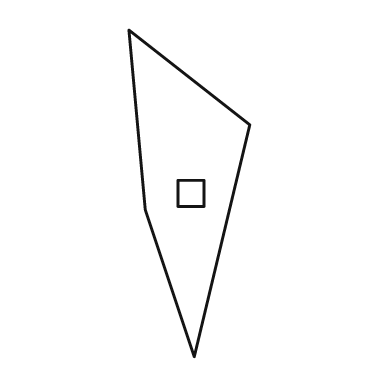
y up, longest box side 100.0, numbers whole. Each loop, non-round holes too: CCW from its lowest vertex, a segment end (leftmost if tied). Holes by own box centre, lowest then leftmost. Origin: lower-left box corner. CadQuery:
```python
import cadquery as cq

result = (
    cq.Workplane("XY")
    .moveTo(20.0, 0.0)
    .lineTo(37.0, 71.0)
    .lineTo(0.0, 100.0)
    .lineTo(5.0, 45.0)
    .close()
    .moveTo(15.0, 46.0)
    .lineTo(23.0, 46.0)
    .lineTo(23.0, 54.0)
    .lineTo(15.0, 54.0)
    .close()
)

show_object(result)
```